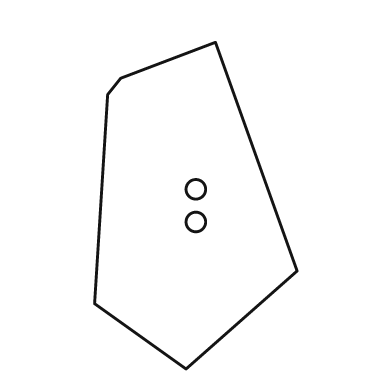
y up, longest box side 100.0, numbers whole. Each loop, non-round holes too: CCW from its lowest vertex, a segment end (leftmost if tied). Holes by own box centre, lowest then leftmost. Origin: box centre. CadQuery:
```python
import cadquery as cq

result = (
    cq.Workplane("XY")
    .moveTo(-3.0, -50.0)
    .lineTo(31.0, -20.0)
    .lineTo(6.0, 50.0)
    .lineTo(-23.0, 39.0)
    .lineTo(-27.0, 34.0)
    .lineTo(-31.0, -30.0)
    .close()
    .moveTo(0.0, -5.0)
    .circle(3.0)
    .moveTo(0.0, 5.0)
    .circle(3.0)
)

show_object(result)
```